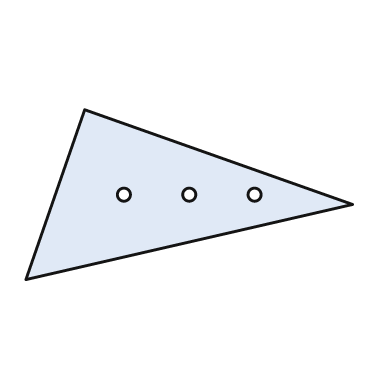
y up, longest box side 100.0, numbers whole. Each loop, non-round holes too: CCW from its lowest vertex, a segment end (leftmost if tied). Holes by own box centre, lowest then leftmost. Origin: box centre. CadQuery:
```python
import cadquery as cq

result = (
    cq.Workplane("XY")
    .moveTo(-50.0, -26.0)
    .lineTo(50.0, -3.0)
    .lineTo(-32.0, 26.0)
    .close()
    .moveTo(-20.0, 0.0)
    .circle(2.0)
    .moveTo(0.0, 0.0)
    .circle(2.0)
    .moveTo(20.0, 0.0)
    .circle(2.0)
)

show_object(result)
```